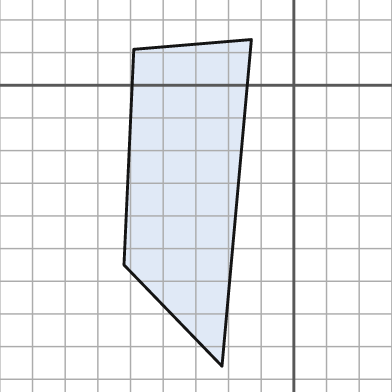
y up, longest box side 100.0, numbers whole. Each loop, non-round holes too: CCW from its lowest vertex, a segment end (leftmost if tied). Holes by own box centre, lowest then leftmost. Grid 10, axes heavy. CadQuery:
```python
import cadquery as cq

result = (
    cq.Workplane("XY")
    .moveTo(-22.0, -86.0)
    .lineTo(-13.0, 14.0)
    .lineTo(-49.0, 11.0)
    .lineTo(-52.0, -55.0)
    .close()
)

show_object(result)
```